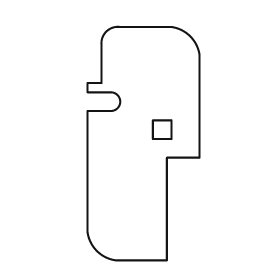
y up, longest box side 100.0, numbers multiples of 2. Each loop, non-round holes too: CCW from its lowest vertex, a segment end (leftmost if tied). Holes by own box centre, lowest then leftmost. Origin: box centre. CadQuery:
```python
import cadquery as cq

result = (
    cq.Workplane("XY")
    .moveTo(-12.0, -50.0)
    .lineTo(10.0, -50.0)
    .lineTo(10.0, -6.0)
    .lineTo(24.0, -6.0)
    .lineTo(24.0, 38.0)
    .threePointArc((20.0, 46.0), (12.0, 50.0))
    .lineTo(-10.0, 50.0)
    .threePointArc((-16.0, 48.0), (-18.0, 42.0))
    .lineTo(-18.0, 26.0)
    .lineTo(-24.0, 26.0)
    .lineTo(-24.0, 22.0)
    .lineTo(-14.0, 22.0)
    .threePointArc((-10.0, 18.0), (-14.0, 14.0))
    .lineTo(-24.0, 14.0)
    .lineTo(-24.0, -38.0)
    .threePointArc((-20.0, -46.0), (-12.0, -50.0))
    .close()
    .moveTo(4.0, 2.0)
    .lineTo(12.0, 2.0)
    .lineTo(12.0, 10.0)
    .lineTo(4.0, 10.0)
    .close()
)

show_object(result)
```